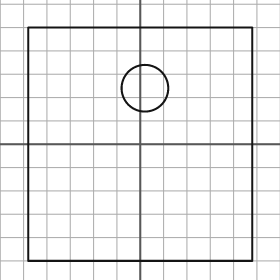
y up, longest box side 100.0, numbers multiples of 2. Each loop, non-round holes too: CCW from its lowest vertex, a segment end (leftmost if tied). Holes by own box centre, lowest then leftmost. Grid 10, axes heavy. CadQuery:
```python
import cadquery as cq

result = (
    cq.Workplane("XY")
    .moveTo(-48.0, -50.0)
    .lineTo(48.0, -50.0)
    .lineTo(48.0, 50.0)
    .lineTo(-48.0, 50.0)
    .close()
    .moveTo(2.0, 24.0)
    .circle(10.0)
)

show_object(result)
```